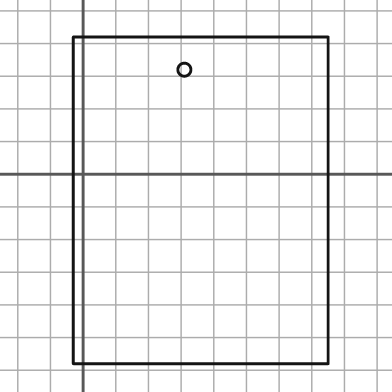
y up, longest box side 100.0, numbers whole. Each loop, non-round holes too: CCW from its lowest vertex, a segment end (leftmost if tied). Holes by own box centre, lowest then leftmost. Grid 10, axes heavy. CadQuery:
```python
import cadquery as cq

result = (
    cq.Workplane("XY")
    .moveTo(-3.0, -58.0)
    .lineTo(75.0, -58.0)
    .lineTo(75.0, 42.0)
    .lineTo(-3.0, 42.0)
    .close()
    .moveTo(31.0, 32.0)
    .circle(2.0)
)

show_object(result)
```